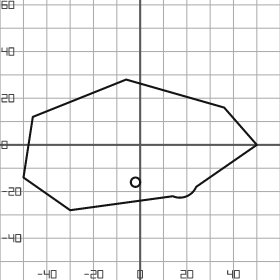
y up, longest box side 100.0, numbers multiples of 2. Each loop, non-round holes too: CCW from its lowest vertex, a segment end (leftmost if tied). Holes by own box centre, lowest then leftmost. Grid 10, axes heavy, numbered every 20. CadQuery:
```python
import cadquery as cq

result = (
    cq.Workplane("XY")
    .moveTo(-30.0, -28.0)
    .lineTo(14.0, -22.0)
    .threePointArc((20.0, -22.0), (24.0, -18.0))
    .lineTo(50.0, 0.0)
    .lineTo(36.0, 16.0)
    .lineTo(-6.0, 28.0)
    .lineTo(-46.0, 12.0)
    .lineTo(-50.0, -14.0)
    .close()
    .moveTo(-2.0, -16.0)
    .circle(2.0)
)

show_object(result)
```